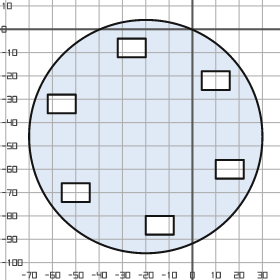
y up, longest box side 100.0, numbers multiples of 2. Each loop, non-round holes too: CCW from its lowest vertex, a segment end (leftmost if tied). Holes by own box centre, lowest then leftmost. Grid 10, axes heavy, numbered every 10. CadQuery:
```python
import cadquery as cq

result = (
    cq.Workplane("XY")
    .moveTo(-20.0, -46.0)
    .circle(50.0)
    .moveTo(-20.0, -88.0)
    .lineTo(-8.0, -88.0)
    .lineTo(-8.0, -80.0)
    .lineTo(-20.0, -80.0)
    .close()
    .moveTo(-56.0, -74.0)
    .lineTo(-44.0, -74.0)
    .lineTo(-44.0, -66.0)
    .lineTo(-56.0, -66.0)
    .close()
    .moveTo(10.0, -64.0)
    .lineTo(22.0, -64.0)
    .lineTo(22.0, -56.0)
    .lineTo(10.0, -56.0)
    .close()
    .moveTo(-62.0, -36.0)
    .lineTo(-50.0, -36.0)
    .lineTo(-50.0, -28.0)
    .lineTo(-62.0, -28.0)
    .close()
    .moveTo(4.0, -26.0)
    .lineTo(16.0, -26.0)
    .lineTo(16.0, -18.0)
    .lineTo(4.0, -18.0)
    .close()
    .moveTo(-32.0, -12.0)
    .lineTo(-20.0, -12.0)
    .lineTo(-20.0, -4.0)
    .lineTo(-32.0, -4.0)
    .close()
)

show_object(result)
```